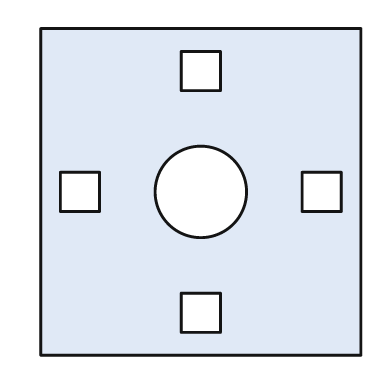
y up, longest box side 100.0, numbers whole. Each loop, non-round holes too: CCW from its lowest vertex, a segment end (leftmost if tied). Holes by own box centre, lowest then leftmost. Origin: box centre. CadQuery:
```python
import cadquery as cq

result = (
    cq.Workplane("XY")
    .moveTo(-49.0, -50.0)
    .lineTo(49.0, -50.0)
    .lineTo(49.0, 50.0)
    .lineTo(-49.0, 50.0)
    .close()
    .moveTo(-6.0, -43.0)
    .lineTo(6.0, -43.0)
    .lineTo(6.0, -31.0)
    .lineTo(-6.0, -31.0)
    .close()
    .moveTo(-43.0, -6.0)
    .lineTo(-31.0, -6.0)
    .lineTo(-31.0, 6.0)
    .lineTo(-43.0, 6.0)
    .close()
    .moveTo(0.0, 0.0)
    .circle(14.0)
    .moveTo(31.0, -6.0)
    .lineTo(43.0, -6.0)
    .lineTo(43.0, 6.0)
    .lineTo(31.0, 6.0)
    .close()
    .moveTo(-6.0, 31.0)
    .lineTo(6.0, 31.0)
    .lineTo(6.0, 43.0)
    .lineTo(-6.0, 43.0)
    .close()
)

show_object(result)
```